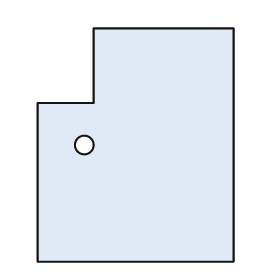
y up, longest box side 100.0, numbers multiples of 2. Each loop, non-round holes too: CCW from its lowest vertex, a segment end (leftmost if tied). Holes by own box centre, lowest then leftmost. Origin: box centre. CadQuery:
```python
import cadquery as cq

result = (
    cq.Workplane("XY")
    .moveTo(-42.0, -50.0)
    .lineTo(42.0, -50.0)
    .lineTo(42.0, 50.0)
    .lineTo(-18.0, 50.0)
    .lineTo(-18.0, 18.0)
    .lineTo(-42.0, 18.0)
    .close()
    .moveTo(-22.0, 0.0)
    .circle(4.0)
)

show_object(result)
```